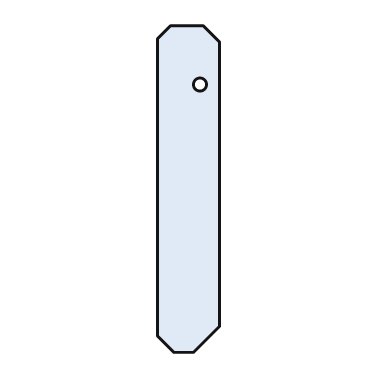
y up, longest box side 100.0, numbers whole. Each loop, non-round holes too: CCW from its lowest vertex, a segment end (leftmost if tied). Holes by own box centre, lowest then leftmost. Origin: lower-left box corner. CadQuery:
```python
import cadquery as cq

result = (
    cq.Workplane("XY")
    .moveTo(5.0, 0.0)
    .lineTo(11.0, 0.0)
    .lineTo(19.0, 8.0)
    .lineTo(19.0, 95.0)
    .lineTo(14.0, 100.0)
    .lineTo(4.0, 100.0)
    .lineTo(0.0, 96.0)
    .lineTo(0.0, 5.0)
    .close()
    .moveTo(13.0, 82.0)
    .circle(2.0)
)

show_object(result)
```